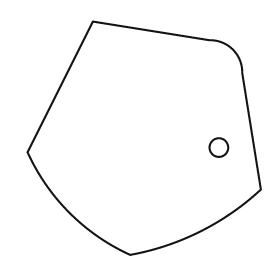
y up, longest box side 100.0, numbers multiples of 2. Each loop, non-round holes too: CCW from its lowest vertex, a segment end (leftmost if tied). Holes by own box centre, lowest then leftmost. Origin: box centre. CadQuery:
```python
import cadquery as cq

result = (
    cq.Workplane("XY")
    .moveTo(-6.0, -50.0)
    .threePointArc((24.0, -40.0), (50.0, -22.0))
    .lineTo(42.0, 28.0)
    .threePointArc((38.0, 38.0), (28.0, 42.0))
    .lineTo(-22.0, 50.0)
    .lineTo(-50.0, -6.0)
    .threePointArc((-32.0, -32.0), (-6.0, -50.0))
    .close()
    .moveTo(32.0, -4.0)
    .circle(4.0)
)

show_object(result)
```